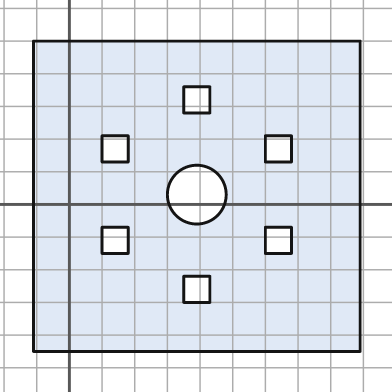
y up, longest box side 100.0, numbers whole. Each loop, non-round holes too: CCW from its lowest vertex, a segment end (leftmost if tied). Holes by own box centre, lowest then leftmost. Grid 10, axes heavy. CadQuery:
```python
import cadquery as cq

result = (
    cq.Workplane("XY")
    .moveTo(-11.0, -45.0)
    .lineTo(89.0, -45.0)
    .lineTo(89.0, 50.0)
    .lineTo(-11.0, 50.0)
    .close()
    .moveTo(35.0, -30.0)
    .lineTo(43.0, -30.0)
    .lineTo(43.0, -22.0)
    .lineTo(35.0, -22.0)
    .close()
    .moveTo(10.0, -15.0)
    .lineTo(18.0, -15.0)
    .lineTo(18.0, -7.0)
    .lineTo(10.0, -7.0)
    .close()
    .moveTo(60.0, -15.0)
    .lineTo(68.0, -15.0)
    .lineTo(68.0, -7.0)
    .lineTo(60.0, -7.0)
    .close()
    .moveTo(39.0, 3.0)
    .circle(9.0)
    .moveTo(10.0, 13.0)
    .lineTo(18.0, 13.0)
    .lineTo(18.0, 21.0)
    .lineTo(10.0, 21.0)
    .close()
    .moveTo(60.0, 13.0)
    .lineTo(68.0, 13.0)
    .lineTo(68.0, 21.0)
    .lineTo(60.0, 21.0)
    .close()
    .moveTo(35.0, 28.0)
    .lineTo(43.0, 28.0)
    .lineTo(43.0, 36.0)
    .lineTo(35.0, 36.0)
    .close()
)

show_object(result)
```